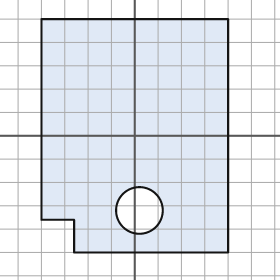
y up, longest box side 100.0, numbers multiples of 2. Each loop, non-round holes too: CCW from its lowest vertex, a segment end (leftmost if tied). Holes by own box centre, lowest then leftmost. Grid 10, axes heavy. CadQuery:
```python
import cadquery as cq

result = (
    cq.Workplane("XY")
    .moveTo(-26.0, -50.0)
    .lineTo(40.0, -50.0)
    .lineTo(40.0, 50.0)
    .lineTo(-40.0, 50.0)
    .lineTo(-40.0, -36.0)
    .lineTo(-26.0, -36.0)
    .close()
    .moveTo(2.0, -32.0)
    .circle(10.0)
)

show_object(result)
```